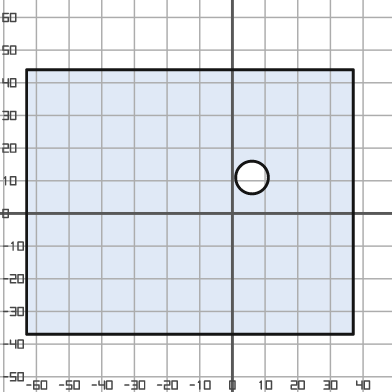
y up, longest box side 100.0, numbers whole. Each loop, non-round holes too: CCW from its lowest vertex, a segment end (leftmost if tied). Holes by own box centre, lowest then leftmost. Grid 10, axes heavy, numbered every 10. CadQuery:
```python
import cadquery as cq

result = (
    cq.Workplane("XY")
    .moveTo(-63.0, -37.0)
    .lineTo(37.0, -37.0)
    .lineTo(37.0, 44.0)
    .lineTo(-63.0, 44.0)
    .close()
    .moveTo(6.0, 11.0)
    .circle(5.0)
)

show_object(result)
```